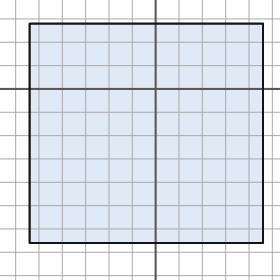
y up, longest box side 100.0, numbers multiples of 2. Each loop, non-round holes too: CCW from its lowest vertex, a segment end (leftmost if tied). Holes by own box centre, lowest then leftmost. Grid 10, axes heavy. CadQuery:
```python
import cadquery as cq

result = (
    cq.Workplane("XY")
    .moveTo(-54.0, -66.0)
    .lineTo(46.0, -66.0)
    .lineTo(46.0, 28.0)
    .lineTo(-54.0, 28.0)
    .close()
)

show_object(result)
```